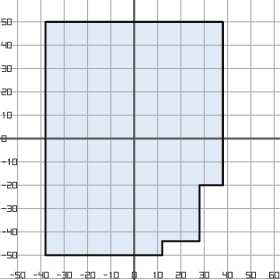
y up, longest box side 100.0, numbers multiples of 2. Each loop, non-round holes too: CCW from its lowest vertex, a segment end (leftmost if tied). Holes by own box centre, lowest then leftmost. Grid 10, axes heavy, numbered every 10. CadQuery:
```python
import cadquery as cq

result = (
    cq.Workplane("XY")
    .moveTo(-38.0, -50.0)
    .lineTo(12.0, -50.0)
    .lineTo(12.0, -44.0)
    .lineTo(28.0, -44.0)
    .lineTo(28.0, -20.0)
    .lineTo(38.0, -20.0)
    .lineTo(38.0, 50.0)
    .lineTo(-38.0, 50.0)
    .close()
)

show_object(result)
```